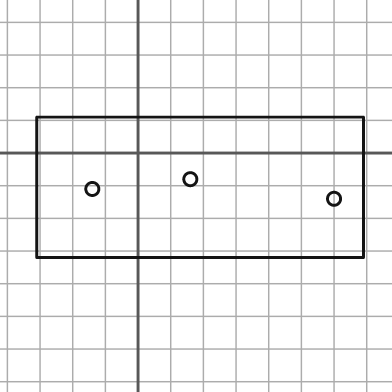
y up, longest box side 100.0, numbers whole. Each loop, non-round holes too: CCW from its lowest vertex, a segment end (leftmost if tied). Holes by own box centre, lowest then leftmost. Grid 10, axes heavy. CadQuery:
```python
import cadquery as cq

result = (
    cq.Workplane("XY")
    .moveTo(-31.0, -32.0)
    .lineTo(69.0, -32.0)
    .lineTo(69.0, 11.0)
    .lineTo(-31.0, 11.0)
    .close()
    .moveTo(60.0, -14.0)
    .circle(2.0)
    .moveTo(-14.0, -11.0)
    .circle(2.0)
    .moveTo(16.0, -8.0)
    .circle(2.0)
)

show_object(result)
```